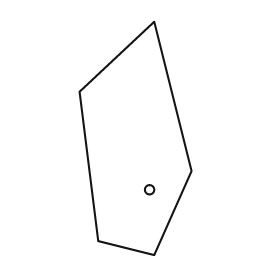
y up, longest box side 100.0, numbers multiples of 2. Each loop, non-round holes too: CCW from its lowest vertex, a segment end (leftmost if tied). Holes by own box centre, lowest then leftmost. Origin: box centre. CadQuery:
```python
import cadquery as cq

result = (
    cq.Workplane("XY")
    .moveTo(8.0, -50.0)
    .lineTo(24.0, -14.0)
    .lineTo(8.0, 50.0)
    .lineTo(-24.0, 20.0)
    .lineTo(-16.0, -44.0)
    .close()
    .moveTo(6.0, -22.0)
    .circle(2.0)
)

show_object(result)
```